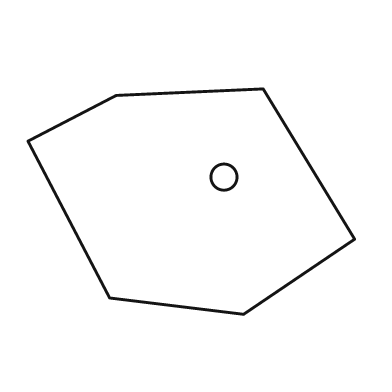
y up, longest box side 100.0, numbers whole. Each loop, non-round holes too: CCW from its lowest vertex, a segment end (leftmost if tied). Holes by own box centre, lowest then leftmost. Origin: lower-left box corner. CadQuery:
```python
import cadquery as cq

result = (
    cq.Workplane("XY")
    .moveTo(66.0, 0.0)
    .lineTo(100.0, 23.0)
    .lineTo(72.0, 69.0)
    .lineTo(27.0, 67.0)
    .lineTo(0.0, 53.0)
    .lineTo(25.0, 5.0)
    .close()
    .moveTo(60.0, 42.0)
    .circle(4.0)
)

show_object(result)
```